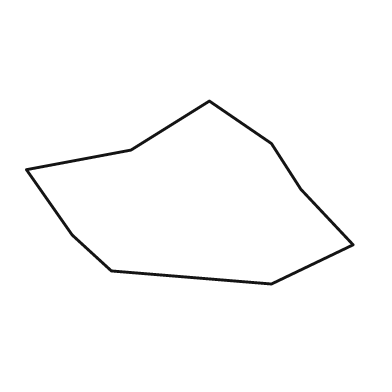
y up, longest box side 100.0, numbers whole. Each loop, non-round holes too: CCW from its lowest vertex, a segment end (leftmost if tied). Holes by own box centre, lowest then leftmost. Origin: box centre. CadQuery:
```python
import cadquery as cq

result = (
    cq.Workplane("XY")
    .moveTo(25.0, -28.0)
    .lineTo(50.0, -16.0)
    .lineTo(34.0, 1.0)
    .lineTo(25.0, 15.0)
    .lineTo(6.0, 28.0)
    .lineTo(-18.0, 13.0)
    .lineTo(-50.0, 7.0)
    .lineTo(-36.0, -13.0)
    .lineTo(-24.0, -24.0)
    .close()
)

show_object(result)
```